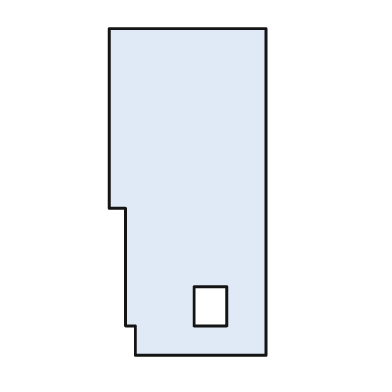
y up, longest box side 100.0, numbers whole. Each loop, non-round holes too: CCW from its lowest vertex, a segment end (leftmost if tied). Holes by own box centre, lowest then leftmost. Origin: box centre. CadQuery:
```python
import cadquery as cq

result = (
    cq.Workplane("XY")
    .moveTo(-16.0, -50.0)
    .lineTo(24.0, -50.0)
    .lineTo(24.0, 50.0)
    .lineTo(-24.0, 50.0)
    .lineTo(-24.0, -5.0)
    .lineTo(-19.0, -5.0)
    .lineTo(-19.0, -41.0)
    .lineTo(-16.0, -41.0)
    .close()
    .moveTo(2.0, -41.0)
    .lineTo(12.0, -41.0)
    .lineTo(12.0, -29.0)
    .lineTo(2.0, -29.0)
    .close()
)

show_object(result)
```